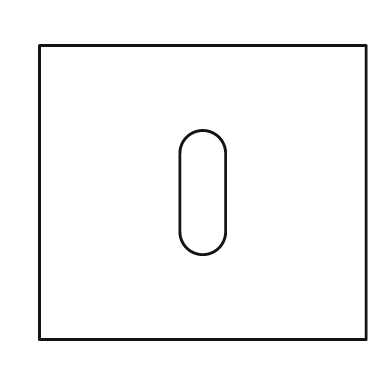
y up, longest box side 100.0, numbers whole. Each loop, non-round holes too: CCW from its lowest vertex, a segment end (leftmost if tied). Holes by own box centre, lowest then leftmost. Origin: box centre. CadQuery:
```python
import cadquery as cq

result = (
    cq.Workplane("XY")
    .moveTo(-50.0, -45.0)
    .lineTo(50.0, -45.0)
    .lineTo(50.0, 45.0)
    .lineTo(-50.0, 45.0)
    .close()
    .moveTo(-7.0, -12.0)
    .threePointArc((0.0, -19.0), (7.0, -12.0))
    .lineTo(7.0, 12.0)
    .threePointArc((0.0, 19.0), (-7.0, 12.0))
    .close()
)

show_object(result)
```